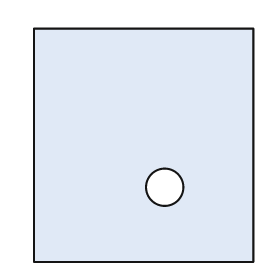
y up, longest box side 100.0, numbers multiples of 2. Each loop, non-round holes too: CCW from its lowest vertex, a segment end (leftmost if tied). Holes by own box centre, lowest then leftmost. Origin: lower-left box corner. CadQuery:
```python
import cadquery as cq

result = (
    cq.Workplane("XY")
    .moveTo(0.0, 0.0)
    .lineTo(94.0, 0.0)
    .lineTo(94.0, 100.0)
    .lineTo(0.0, 100.0)
    .close()
    .moveTo(56.0, 32.0)
    .circle(8.0)
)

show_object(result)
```